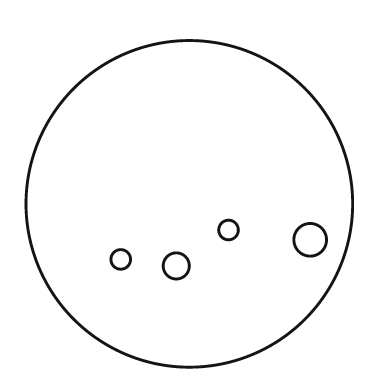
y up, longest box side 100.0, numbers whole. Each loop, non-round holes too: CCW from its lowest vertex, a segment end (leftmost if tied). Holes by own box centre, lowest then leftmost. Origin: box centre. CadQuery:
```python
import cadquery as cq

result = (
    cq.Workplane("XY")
    .moveTo(0.0, 0.0)
    .circle(50.0)
    .moveTo(-4.0, -19.0)
    .circle(4.0)
    .moveTo(-21.0, -17.0)
    .circle(3.0)
    .moveTo(37.0, -11.0)
    .circle(5.0)
    .moveTo(12.0, -8.0)
    .circle(3.0)
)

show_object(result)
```